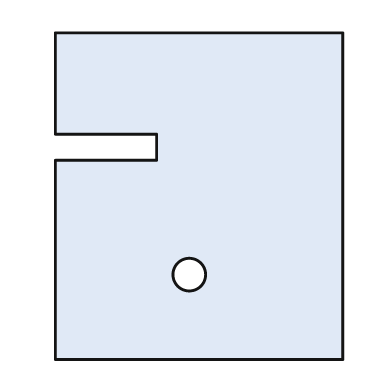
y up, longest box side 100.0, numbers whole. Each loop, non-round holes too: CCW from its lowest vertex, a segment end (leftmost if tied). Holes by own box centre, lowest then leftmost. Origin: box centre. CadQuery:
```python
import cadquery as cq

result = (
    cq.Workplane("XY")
    .moveTo(-44.0, -50.0)
    .lineTo(44.0, -50.0)
    .lineTo(44.0, 50.0)
    .lineTo(-44.0, 50.0)
    .lineTo(-44.0, 19.0)
    .lineTo(-13.0, 19.0)
    .lineTo(-13.0, 11.0)
    .lineTo(-44.0, 11.0)
    .close()
    .moveTo(-3.0, -24.0)
    .circle(5.0)
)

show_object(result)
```